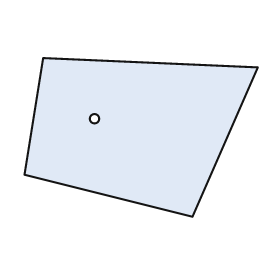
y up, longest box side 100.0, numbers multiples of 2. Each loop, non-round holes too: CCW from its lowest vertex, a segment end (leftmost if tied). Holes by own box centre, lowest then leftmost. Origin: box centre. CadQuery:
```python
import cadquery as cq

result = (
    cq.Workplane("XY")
    .moveTo(22.0, -34.0)
    .lineTo(50.0, 30.0)
    .lineTo(-42.0, 34.0)
    .lineTo(-50.0, -16.0)
    .close()
    .moveTo(-20.0, 8.0)
    .circle(2.0)
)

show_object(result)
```